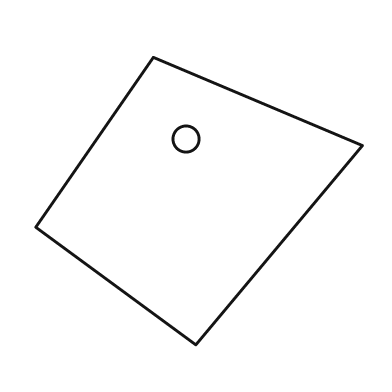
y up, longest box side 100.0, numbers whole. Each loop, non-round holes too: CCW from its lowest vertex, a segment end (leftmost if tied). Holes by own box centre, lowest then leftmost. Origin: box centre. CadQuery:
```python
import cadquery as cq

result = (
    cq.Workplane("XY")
    .moveTo(-1.0, -44.0)
    .lineTo(50.0, 17.0)
    .lineTo(-14.0, 44.0)
    .lineTo(-50.0, -8.0)
    .close()
    .moveTo(-4.0, 19.0)
    .circle(4.0)
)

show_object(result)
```